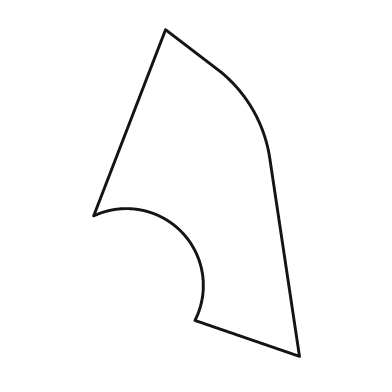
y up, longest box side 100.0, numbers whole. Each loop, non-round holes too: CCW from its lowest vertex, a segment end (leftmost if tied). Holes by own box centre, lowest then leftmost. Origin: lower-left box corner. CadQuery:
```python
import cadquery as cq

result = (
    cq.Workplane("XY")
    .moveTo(63.0, 0.0)
    .lineTo(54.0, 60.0)
    .threePointArc((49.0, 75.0), (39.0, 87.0))
    .lineTo(22.0, 100.0)
    .lineTo(0.0, 43.0)
    .threePointArc((27.0, 38.0), (31.0, 11.0))
    .close()
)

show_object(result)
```